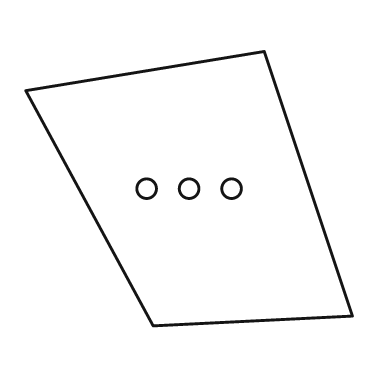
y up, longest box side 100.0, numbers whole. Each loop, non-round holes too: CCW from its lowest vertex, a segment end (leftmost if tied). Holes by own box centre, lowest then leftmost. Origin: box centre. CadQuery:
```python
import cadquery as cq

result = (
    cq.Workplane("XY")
    .moveTo(-11.0, -42.0)
    .lineTo(50.0, -39.0)
    .lineTo(23.0, 42.0)
    .lineTo(-50.0, 30.0)
    .close()
    .moveTo(-13.0, 0.0)
    .circle(3.0)
    .moveTo(0.0, 0.0)
    .circle(3.0)
    .moveTo(13.0, 0.0)
    .circle(3.0)
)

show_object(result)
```